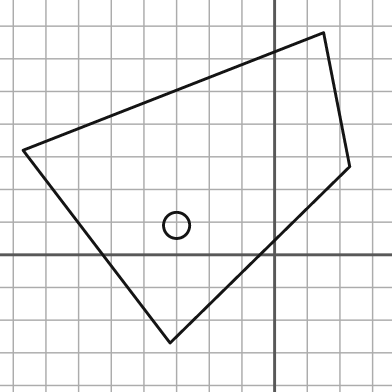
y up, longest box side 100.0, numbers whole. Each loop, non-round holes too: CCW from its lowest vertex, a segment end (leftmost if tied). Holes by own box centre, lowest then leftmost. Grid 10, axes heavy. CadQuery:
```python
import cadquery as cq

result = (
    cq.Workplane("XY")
    .moveTo(-32.0, -27.0)
    .lineTo(23.0, 27.0)
    .lineTo(15.0, 68.0)
    .lineTo(-77.0, 32.0)
    .close()
    .moveTo(-30.0, 9.0)
    .circle(4.0)
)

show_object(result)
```